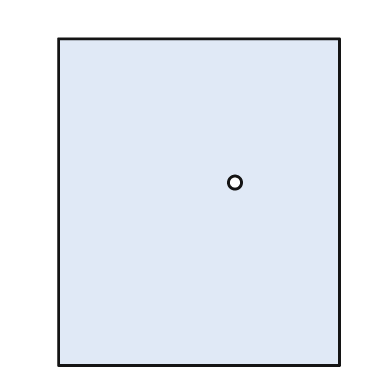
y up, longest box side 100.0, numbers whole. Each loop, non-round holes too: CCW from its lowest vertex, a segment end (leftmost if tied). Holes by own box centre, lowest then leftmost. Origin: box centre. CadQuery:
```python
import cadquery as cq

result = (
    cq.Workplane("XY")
    .moveTo(-43.0, -50.0)
    .lineTo(43.0, -50.0)
    .lineTo(43.0, 50.0)
    .lineTo(-43.0, 50.0)
    .close()
    .moveTo(11.0, 6.0)
    .circle(2.0)
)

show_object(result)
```